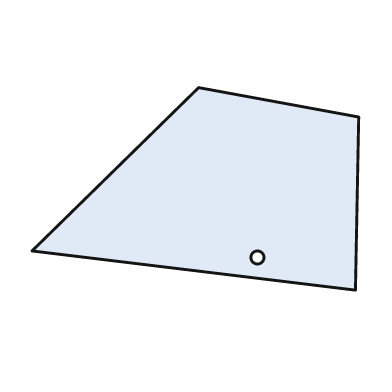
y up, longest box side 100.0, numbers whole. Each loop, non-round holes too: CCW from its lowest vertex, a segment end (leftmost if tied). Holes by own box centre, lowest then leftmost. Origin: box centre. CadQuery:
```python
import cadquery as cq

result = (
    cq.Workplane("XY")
    .moveTo(49.0, -31.0)
    .lineTo(50.0, 22.0)
    .lineTo(1.0, 31.0)
    .lineTo(-50.0, -19.0)
    .close()
    .moveTo(19.0, -21.0)
    .circle(2.0)
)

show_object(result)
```